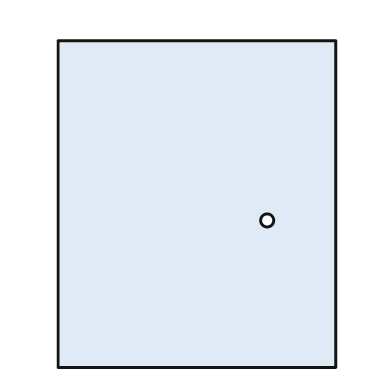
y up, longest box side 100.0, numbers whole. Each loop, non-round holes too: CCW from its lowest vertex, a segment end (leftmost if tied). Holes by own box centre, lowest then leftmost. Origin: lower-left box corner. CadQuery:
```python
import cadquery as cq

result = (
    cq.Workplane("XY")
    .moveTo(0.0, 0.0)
    .lineTo(85.0, 0.0)
    .lineTo(85.0, 100.0)
    .lineTo(0.0, 100.0)
    .close()
    .moveTo(64.0, 45.0)
    .circle(2.0)
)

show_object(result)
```